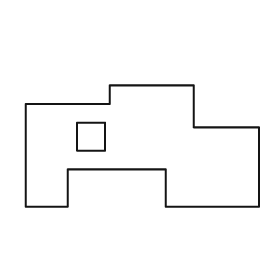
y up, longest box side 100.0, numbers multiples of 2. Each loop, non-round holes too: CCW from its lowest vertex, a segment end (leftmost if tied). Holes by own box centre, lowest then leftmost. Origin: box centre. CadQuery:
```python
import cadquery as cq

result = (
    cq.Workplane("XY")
    .moveTo(-50.0, -26.0)
    .lineTo(-32.0, -26.0)
    .lineTo(-32.0, -10.0)
    .lineTo(10.0, -10.0)
    .lineTo(10.0, -26.0)
    .lineTo(50.0, -26.0)
    .lineTo(50.0, 8.0)
    .lineTo(22.0, 8.0)
    .lineTo(22.0, 26.0)
    .lineTo(-14.0, 26.0)
    .lineTo(-14.0, 18.0)
    .lineTo(-50.0, 18.0)
    .close()
    .moveTo(-28.0, -2.0)
    .lineTo(-16.0, -2.0)
    .lineTo(-16.0, 10.0)
    .lineTo(-28.0, 10.0)
    .close()
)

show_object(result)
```